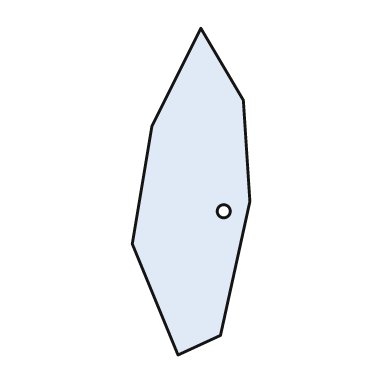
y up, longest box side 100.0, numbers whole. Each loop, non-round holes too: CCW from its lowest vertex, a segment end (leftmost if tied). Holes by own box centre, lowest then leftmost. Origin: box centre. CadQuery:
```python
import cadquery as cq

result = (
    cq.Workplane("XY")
    .moveTo(-4.0, -50.0)
    .lineTo(9.0, -44.0)
    .lineTo(18.0, -3.0)
    .lineTo(16.0, 28.0)
    .lineTo(3.0, 50.0)
    .lineTo(-12.0, 20.0)
    .lineTo(-18.0, -16.0)
    .close()
    .moveTo(10.0, -6.0)
    .circle(2.0)
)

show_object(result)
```